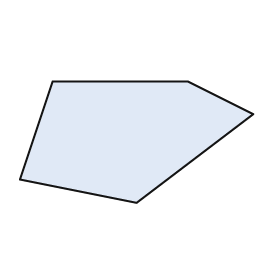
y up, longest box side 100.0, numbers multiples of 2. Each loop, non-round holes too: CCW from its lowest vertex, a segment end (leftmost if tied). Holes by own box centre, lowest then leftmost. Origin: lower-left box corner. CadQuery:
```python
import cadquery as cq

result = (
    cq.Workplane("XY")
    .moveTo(50.0, 0.0)
    .lineTo(100.0, 38.0)
    .lineTo(72.0, 52.0)
    .lineTo(14.0, 52.0)
    .lineTo(0.0, 10.0)
    .close()
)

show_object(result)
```